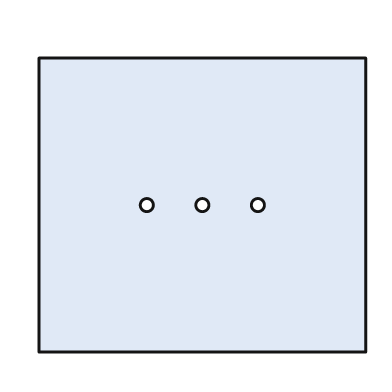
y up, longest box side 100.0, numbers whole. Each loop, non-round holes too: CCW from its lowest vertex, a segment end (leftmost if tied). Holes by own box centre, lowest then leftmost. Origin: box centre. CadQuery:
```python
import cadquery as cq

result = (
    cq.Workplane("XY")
    .moveTo(-50.0, -45.0)
    .lineTo(50.0, -45.0)
    .lineTo(50.0, 45.0)
    .lineTo(-50.0, 45.0)
    .close()
    .moveTo(-17.0, 0.0)
    .circle(2.0)
    .moveTo(0.0, 0.0)
    .circle(2.0)
    .moveTo(17.0, 0.0)
    .circle(2.0)
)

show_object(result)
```